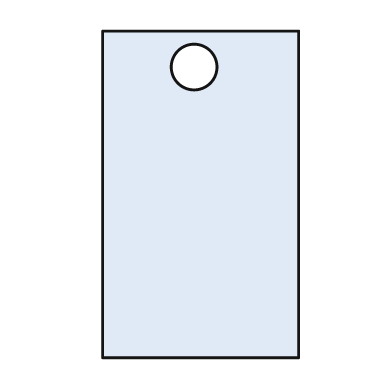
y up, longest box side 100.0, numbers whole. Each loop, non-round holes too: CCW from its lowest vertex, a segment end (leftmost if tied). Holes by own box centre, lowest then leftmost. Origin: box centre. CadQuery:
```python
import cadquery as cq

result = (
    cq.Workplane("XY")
    .moveTo(-30.0, -50.0)
    .lineTo(30.0, -50.0)
    .lineTo(30.0, 50.0)
    .lineTo(-30.0, 50.0)
    .close()
    .moveTo(-2.0, 39.0)
    .circle(7.0)
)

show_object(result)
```